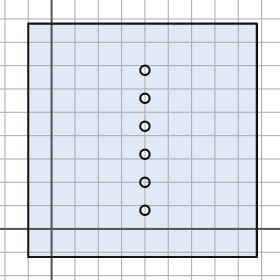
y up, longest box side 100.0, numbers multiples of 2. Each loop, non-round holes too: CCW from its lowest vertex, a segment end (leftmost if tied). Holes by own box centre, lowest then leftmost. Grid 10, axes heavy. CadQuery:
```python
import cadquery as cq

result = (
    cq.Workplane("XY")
    .moveTo(-10.0, -12.0)
    .lineTo(88.0, -12.0)
    .lineTo(88.0, 88.0)
    .lineTo(-10.0, 88.0)
    .close()
    .moveTo(40.0, 8.0)
    .circle(2.0)
    .moveTo(40.0, 20.0)
    .circle(2.0)
    .moveTo(40.0, 32.0)
    .circle(2.0)
    .moveTo(40.0, 44.0)
    .circle(2.0)
    .moveTo(40.0, 56.0)
    .circle(2.0)
    .moveTo(40.0, 68.0)
    .circle(2.0)
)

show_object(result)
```